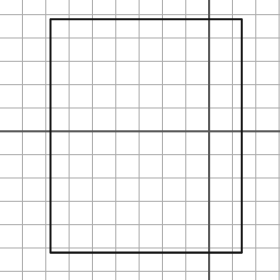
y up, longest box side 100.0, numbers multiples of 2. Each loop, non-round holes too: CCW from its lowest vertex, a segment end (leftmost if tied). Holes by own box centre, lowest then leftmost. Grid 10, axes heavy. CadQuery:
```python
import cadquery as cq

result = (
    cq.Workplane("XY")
    .moveTo(-68.0, -52.0)
    .lineTo(14.0, -52.0)
    .lineTo(14.0, 48.0)
    .lineTo(-68.0, 48.0)
    .close()
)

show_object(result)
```